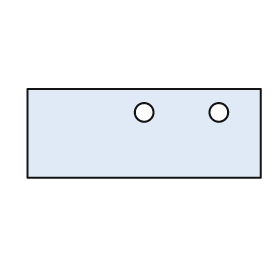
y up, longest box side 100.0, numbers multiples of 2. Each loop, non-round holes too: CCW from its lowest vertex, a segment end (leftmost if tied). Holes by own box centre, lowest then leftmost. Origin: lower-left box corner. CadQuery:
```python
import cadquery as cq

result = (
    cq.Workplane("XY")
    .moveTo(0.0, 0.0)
    .lineTo(100.0, 0.0)
    .lineTo(100.0, 38.0)
    .lineTo(0.0, 38.0)
    .close()
    .moveTo(50.0, 28.0)
    .circle(4.0)
    .moveTo(82.0, 28.0)
    .circle(4.0)
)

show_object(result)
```